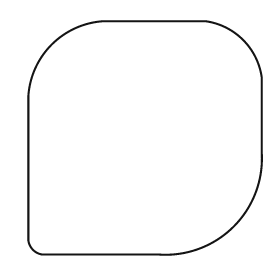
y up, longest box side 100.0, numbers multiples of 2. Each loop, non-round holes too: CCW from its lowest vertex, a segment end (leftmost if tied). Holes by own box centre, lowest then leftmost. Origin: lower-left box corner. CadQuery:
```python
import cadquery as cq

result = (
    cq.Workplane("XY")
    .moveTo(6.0, 0.0)
    .lineTo(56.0, 0.0)
    .threePointArc((88.0, 12.0), (100.0, 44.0))
    .lineTo(100.0, 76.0)
    .threePointArc((92.0, 92.0), (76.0, 100.0))
    .lineTo(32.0, 100.0)
    .threePointArc((10.0, 90.0), (0.0, 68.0))
    .lineTo(0.0, 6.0)
    .threePointArc((2.0, 2.0), (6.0, 0.0))
    .close()
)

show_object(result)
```